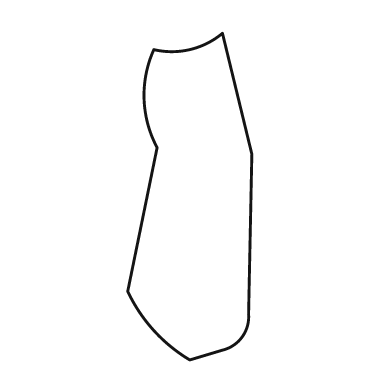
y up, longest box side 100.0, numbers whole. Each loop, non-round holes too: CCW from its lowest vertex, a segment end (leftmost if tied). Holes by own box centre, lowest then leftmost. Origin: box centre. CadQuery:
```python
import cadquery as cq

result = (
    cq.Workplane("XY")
    .moveTo(0.0, -50.0)
    .lineTo(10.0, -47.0)
    .threePointArc((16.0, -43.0), (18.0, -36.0))
    .lineTo(19.0, 13.0)
    .lineTo(10.0, 50.0)
    .threePointArc((0.0, 45.0), (-11.0, 45.0))
    .threePointArc((-14.0, 30.0), (-10.0, 15.0))
    .lineTo(-19.0, -29.0)
    .threePointArc((-11.0, -41.0), (0.0, -50.0))
    .close()
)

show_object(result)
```